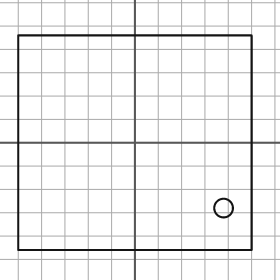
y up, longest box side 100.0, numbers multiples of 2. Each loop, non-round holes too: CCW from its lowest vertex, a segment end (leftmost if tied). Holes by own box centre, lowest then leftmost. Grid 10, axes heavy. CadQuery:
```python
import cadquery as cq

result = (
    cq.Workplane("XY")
    .moveTo(-50.0, -46.0)
    .lineTo(50.0, -46.0)
    .lineTo(50.0, 46.0)
    .lineTo(-50.0, 46.0)
    .close()
    .moveTo(38.0, -28.0)
    .circle(4.0)
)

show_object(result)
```